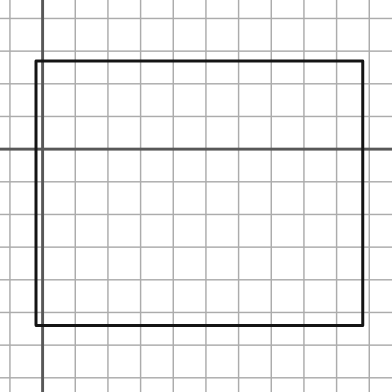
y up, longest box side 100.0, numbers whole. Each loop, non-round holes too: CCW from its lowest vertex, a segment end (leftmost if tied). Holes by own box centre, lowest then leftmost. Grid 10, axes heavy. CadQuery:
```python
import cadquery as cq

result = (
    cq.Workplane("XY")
    .moveTo(-2.0, -54.0)
    .lineTo(98.0, -54.0)
    .lineTo(98.0, 27.0)
    .lineTo(-2.0, 27.0)
    .close()
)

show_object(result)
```